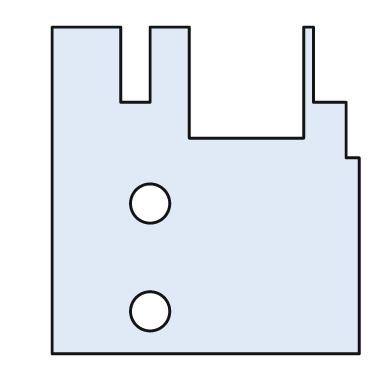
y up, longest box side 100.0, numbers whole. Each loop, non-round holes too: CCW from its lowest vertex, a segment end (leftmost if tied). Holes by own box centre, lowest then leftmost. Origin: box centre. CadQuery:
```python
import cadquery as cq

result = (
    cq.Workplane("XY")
    .moveTo(-47.0, -50.0)
    .lineTo(47.0, -50.0)
    .lineTo(47.0, 10.0)
    .lineTo(43.0, 10.0)
    .lineTo(43.0, 27.0)
    .lineTo(33.0, 27.0)
    .lineTo(33.0, 50.0)
    .lineTo(30.0, 50.0)
    .lineTo(30.0, 16.0)
    .lineTo(-5.0, 16.0)
    .lineTo(-5.0, 50.0)
    .lineTo(-17.0, 50.0)
    .lineTo(-17.0, 27.0)
    .lineTo(-26.0, 27.0)
    .lineTo(-26.0, 50.0)
    .lineTo(-47.0, 50.0)
    .close()
    .moveTo(-17.0, -37.0)
    .circle(6.0)
    .moveTo(-17.0, -4.0)
    .circle(6.0)
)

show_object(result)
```